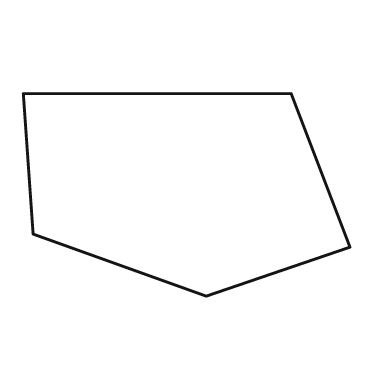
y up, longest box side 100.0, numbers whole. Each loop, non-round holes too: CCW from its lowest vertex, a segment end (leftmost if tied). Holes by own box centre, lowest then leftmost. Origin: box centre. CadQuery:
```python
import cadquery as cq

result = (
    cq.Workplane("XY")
    .moveTo(6.0, -31.0)
    .lineTo(50.0, -16.0)
    .lineTo(32.0, 31.0)
    .lineTo(-50.0, 31.0)
    .lineTo(-47.0, -12.0)
    .close()
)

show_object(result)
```